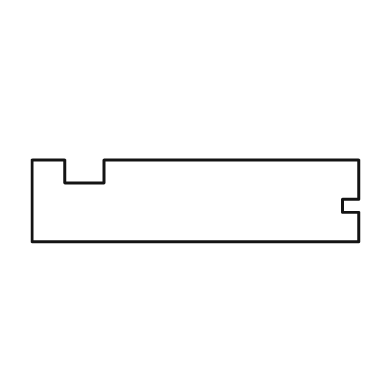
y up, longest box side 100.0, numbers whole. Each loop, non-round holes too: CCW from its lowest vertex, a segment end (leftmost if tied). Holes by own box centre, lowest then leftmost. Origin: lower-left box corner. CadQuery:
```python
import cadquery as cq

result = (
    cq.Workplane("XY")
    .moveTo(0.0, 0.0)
    .lineTo(100.0, 0.0)
    .lineTo(100.0, 9.0)
    .lineTo(95.0, 9.0)
    .lineTo(95.0, 13.0)
    .lineTo(100.0, 13.0)
    .lineTo(100.0, 25.0)
    .lineTo(22.0, 25.0)
    .lineTo(22.0, 18.0)
    .lineTo(10.0, 18.0)
    .lineTo(10.0, 25.0)
    .lineTo(0.0, 25.0)
    .close()
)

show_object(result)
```